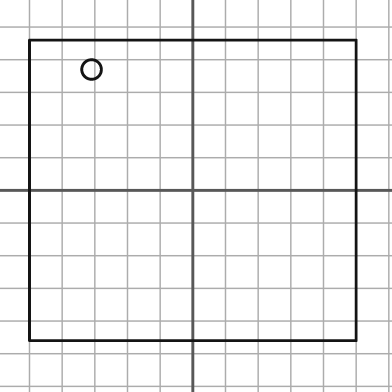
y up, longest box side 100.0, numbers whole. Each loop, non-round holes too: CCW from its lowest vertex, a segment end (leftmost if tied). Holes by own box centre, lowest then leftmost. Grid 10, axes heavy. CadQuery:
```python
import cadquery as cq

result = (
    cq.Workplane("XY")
    .moveTo(-50.0, -46.0)
    .lineTo(50.0, -46.0)
    .lineTo(50.0, 46.0)
    .lineTo(-50.0, 46.0)
    .close()
    .moveTo(-31.0, 37.0)
    .circle(3.0)
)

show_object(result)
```